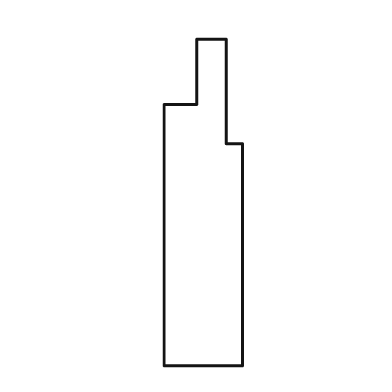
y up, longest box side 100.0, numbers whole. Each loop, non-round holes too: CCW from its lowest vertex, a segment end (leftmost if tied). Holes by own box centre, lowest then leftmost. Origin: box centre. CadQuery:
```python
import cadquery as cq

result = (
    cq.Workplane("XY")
    .moveTo(-12.0, -50.0)
    .lineTo(12.0, -50.0)
    .lineTo(12.0, 18.0)
    .lineTo(7.0, 18.0)
    .lineTo(7.0, 50.0)
    .lineTo(-2.0, 50.0)
    .lineTo(-2.0, 30.0)
    .lineTo(-12.0, 30.0)
    .close()
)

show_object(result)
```